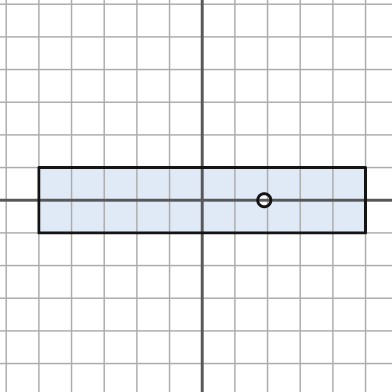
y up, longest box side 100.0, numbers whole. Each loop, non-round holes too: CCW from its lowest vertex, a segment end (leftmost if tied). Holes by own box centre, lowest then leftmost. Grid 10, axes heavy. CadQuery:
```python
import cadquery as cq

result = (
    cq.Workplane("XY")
    .moveTo(-50.0, -10.0)
    .lineTo(50.0, -10.0)
    .lineTo(50.0, 10.0)
    .lineTo(-50.0, 10.0)
    .close()
    .moveTo(19.0, 0.0)
    .circle(2.0)
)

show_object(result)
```